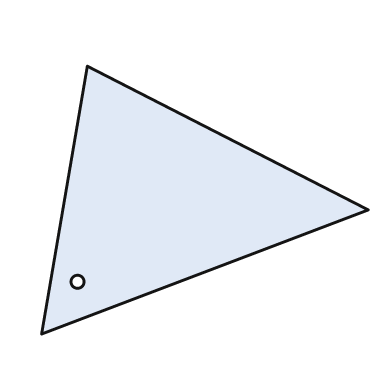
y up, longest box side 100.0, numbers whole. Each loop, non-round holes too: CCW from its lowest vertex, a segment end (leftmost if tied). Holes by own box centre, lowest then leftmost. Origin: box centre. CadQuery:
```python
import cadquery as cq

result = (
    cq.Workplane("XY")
    .moveTo(-50.0, -41.0)
    .lineTo(50.0, -3.0)
    .lineTo(-36.0, 41.0)
    .close()
    .moveTo(-39.0, -25.0)
    .circle(2.0)
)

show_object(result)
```